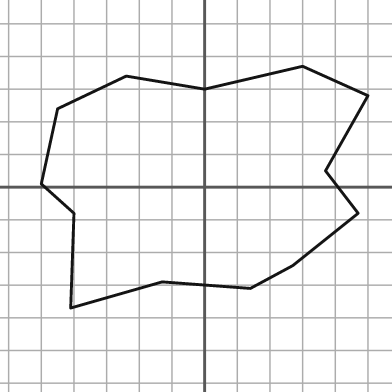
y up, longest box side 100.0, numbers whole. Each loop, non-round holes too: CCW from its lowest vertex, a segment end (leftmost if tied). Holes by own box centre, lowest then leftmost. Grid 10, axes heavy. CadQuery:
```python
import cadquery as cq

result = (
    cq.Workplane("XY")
    .moveTo(-41.0, -37.0)
    .lineTo(-13.0, -29.0)
    .lineTo(14.0, -31.0)
    .lineTo(27.0, -24.0)
    .lineTo(47.0, -8.0)
    .lineTo(37.0, 5.0)
    .lineTo(50.0, 28.0)
    .lineTo(30.0, 37.0)
    .lineTo(0.0, 30.0)
    .lineTo(-24.0, 34.0)
    .lineTo(-45.0, 24.0)
    .lineTo(-50.0, 1.0)
    .lineTo(-40.0, -8.0)
    .close()
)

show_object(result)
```